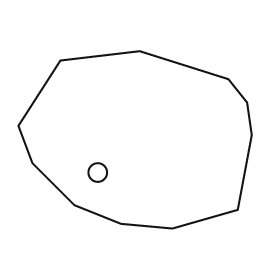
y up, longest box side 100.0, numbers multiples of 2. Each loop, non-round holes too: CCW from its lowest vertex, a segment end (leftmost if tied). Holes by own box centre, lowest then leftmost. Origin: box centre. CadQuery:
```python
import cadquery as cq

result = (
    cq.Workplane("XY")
    .moveTo(16.0, -38.0)
    .lineTo(44.0, -30.0)
    .lineTo(50.0, 2.0)
    .lineTo(48.0, 16.0)
    .lineTo(40.0, 26.0)
    .lineTo(2.0, 38.0)
    .lineTo(-32.0, 34.0)
    .lineTo(-50.0, 6.0)
    .lineTo(-44.0, -10.0)
    .lineTo(-26.0, -28.0)
    .lineTo(-6.0, -36.0)
    .close()
    .moveTo(-16.0, -14.0)
    .circle(4.0)
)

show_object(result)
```